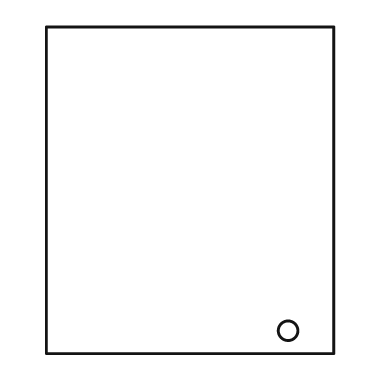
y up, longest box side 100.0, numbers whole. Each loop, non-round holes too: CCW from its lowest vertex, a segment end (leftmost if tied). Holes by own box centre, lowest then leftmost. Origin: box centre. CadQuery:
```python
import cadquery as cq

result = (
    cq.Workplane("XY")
    .moveTo(-44.0, -50.0)
    .lineTo(44.0, -50.0)
    .lineTo(44.0, 50.0)
    .lineTo(-44.0, 50.0)
    .close()
    .moveTo(30.0, -43.0)
    .circle(3.0)
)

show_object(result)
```